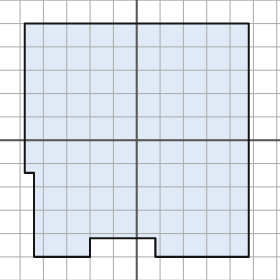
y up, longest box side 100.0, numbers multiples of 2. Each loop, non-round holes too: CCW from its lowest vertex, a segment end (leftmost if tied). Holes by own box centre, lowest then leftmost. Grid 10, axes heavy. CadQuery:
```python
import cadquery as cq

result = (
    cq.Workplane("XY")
    .moveTo(-44.0, -50.0)
    .lineTo(-20.0, -50.0)
    .lineTo(-20.0, -42.0)
    .lineTo(8.0, -42.0)
    .lineTo(8.0, -50.0)
    .lineTo(48.0, -50.0)
    .lineTo(48.0, 50.0)
    .lineTo(-48.0, 50.0)
    .lineTo(-48.0, -14.0)
    .lineTo(-44.0, -14.0)
    .close()
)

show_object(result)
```